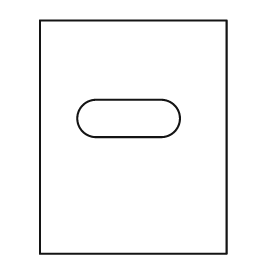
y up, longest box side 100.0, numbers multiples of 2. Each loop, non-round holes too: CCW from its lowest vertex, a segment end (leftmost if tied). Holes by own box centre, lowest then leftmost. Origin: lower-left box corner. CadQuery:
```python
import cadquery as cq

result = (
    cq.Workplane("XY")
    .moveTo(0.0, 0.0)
    .lineTo(80.0, 0.0)
    .lineTo(80.0, 100.0)
    .lineTo(0.0, 100.0)
    .close()
    .moveTo(24.0, 50.0)
    .lineTo(52.0, 50.0)
    .threePointArc((60.0, 58.0), (52.0, 66.0))
    .lineTo(24.0, 66.0)
    .threePointArc((16.0, 58.0), (24.0, 50.0))
    .close()
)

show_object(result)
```